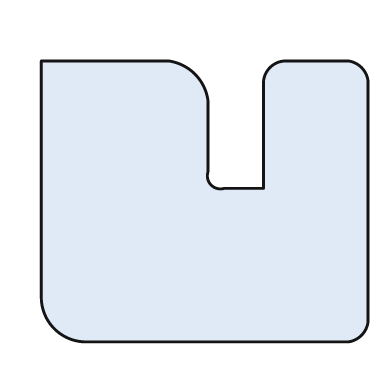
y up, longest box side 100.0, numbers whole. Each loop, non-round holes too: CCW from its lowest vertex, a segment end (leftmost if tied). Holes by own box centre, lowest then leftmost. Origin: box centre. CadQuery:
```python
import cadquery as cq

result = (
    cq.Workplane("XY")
    .moveTo(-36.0, -43.0)
    .lineTo(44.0, -43.0)
    .threePointArc((48.0, -41.0), (50.0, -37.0))
    .lineTo(50.0, 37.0)
    .threePointArc((48.0, 41.0), (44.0, 43.0))
    .lineTo(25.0, 43.0)
    .threePointArc((20.0, 41.0), (18.0, 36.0))
    .lineTo(18.0, 4.0)
    .lineTo(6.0, 4.0)
    .threePointArc((2.0, 5.0), (1.0, 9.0))
    .lineTo(1.0, 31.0)
    .threePointArc((-3.0, 39.0), (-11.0, 43.0))
    .lineTo(-50.0, 43.0)
    .lineTo(-50.0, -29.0)
    .threePointArc((-46.0, -39.0), (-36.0, -43.0))
    .close()
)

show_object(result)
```